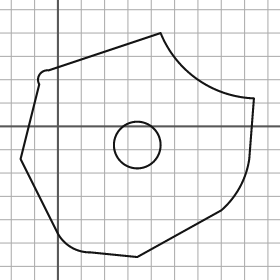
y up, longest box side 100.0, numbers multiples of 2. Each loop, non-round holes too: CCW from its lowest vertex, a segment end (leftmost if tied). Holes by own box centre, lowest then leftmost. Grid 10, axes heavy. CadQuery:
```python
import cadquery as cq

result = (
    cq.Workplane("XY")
    .moveTo(34.0, -56.0)
    .lineTo(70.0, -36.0)
    .threePointArc((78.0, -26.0), (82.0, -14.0))
    .lineTo(84.0, 12.0)
    .threePointArc((60.0, 20.0), (44.0, 40.0))
    .lineTo(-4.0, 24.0)
    .threePointArc((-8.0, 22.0), (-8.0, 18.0))
    .lineTo(-16.0, -14.0)
    .lineTo(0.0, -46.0)
    .threePointArc((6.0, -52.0), (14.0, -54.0))
    .close()
    .moveTo(34.0, -8.0)
    .circle(10.0)
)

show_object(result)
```